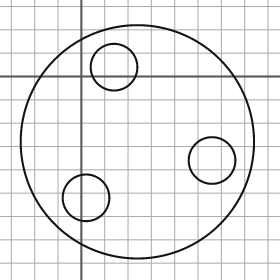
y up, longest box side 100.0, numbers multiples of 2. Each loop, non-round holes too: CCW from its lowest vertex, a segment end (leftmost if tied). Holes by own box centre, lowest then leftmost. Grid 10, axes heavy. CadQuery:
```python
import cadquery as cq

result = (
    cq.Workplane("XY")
    .moveTo(24.0, -28.0)
    .circle(50.0)
    .moveTo(2.0, -52.0)
    .circle(10.0)
    .moveTo(56.0, -36.0)
    .circle(10.0)
    .moveTo(14.0, 4.0)
    .circle(10.0)
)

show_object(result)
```